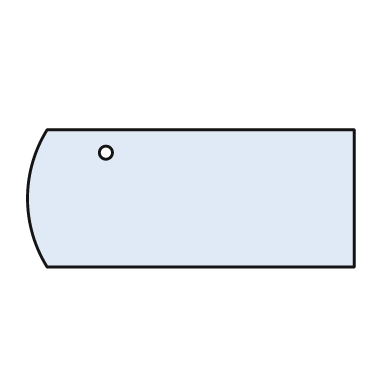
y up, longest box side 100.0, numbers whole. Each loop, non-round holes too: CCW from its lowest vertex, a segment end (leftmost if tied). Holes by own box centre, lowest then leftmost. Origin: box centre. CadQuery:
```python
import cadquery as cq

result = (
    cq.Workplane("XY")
    .moveTo(-44.0, -21.0)
    .lineTo(50.0, -21.0)
    .lineTo(50.0, 21.0)
    .lineTo(-44.0, 21.0)
    .threePointArc((-50.0, 0.0), (-44.0, -21.0))
    .close()
    .moveTo(-26.0, 14.0)
    .circle(2.0)
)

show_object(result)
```